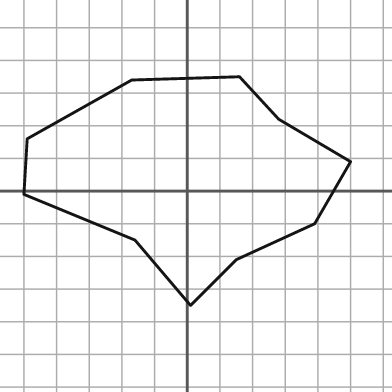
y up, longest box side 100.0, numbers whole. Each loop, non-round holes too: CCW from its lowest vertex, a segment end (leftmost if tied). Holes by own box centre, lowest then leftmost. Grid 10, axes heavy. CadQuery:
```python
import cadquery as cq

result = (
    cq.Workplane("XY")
    .moveTo(1.0, -35.0)
    .lineTo(15.0, -21.0)
    .lineTo(39.0, -10.0)
    .lineTo(50.0, 9.0)
    .lineTo(28.0, 22.0)
    .lineTo(16.0, 35.0)
    .lineTo(-17.0, 34.0)
    .lineTo(-49.0, 16.0)
    .lineTo(-50.0, -1.0)
    .lineTo(-16.0, -15.0)
    .close()
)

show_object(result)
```